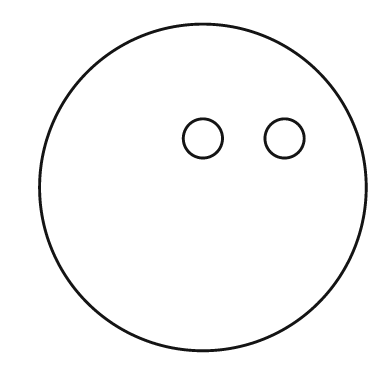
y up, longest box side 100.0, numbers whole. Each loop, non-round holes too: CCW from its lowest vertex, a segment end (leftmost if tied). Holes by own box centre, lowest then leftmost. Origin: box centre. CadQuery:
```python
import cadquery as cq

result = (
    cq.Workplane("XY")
    .moveTo(0.0, 0.0)
    .circle(50.0)
    .moveTo(0.0, 15.0)
    .circle(6.0)
    .moveTo(25.0, 15.0)
    .circle(6.0)
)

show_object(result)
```